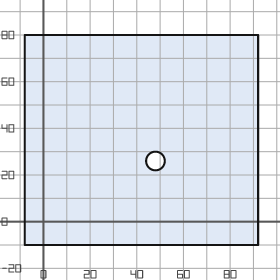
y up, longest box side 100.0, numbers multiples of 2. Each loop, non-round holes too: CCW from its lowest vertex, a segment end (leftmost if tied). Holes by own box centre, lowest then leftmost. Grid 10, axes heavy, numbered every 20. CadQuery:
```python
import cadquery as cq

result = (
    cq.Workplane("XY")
    .moveTo(-8.0, -10.0)
    .lineTo(92.0, -10.0)
    .lineTo(92.0, 80.0)
    .lineTo(-8.0, 80.0)
    .close()
    .moveTo(48.0, 26.0)
    .circle(4.0)
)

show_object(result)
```